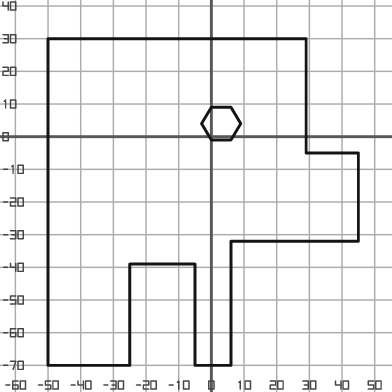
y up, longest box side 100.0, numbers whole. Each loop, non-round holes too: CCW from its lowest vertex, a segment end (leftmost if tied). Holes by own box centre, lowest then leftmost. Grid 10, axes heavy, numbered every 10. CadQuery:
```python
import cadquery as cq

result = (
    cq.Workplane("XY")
    .moveTo(-50.0, -70.0)
    .lineTo(-25.0, -70.0)
    .lineTo(-25.0, -39.0)
    .lineTo(-5.0, -39.0)
    .lineTo(-5.0, -70.0)
    .lineTo(6.0, -70.0)
    .lineTo(6.0, -32.0)
    .lineTo(45.0, -32.0)
    .lineTo(45.0, -5.0)
    .lineTo(29.0, -5.0)
    .lineTo(29.0, 30.0)
    .lineTo(-50.0, 30.0)
    .close()
    .moveTo(0.0, -1.0)
    .lineTo(6.0, -1.0)
    .lineTo(9.0, 4.0)
    .lineTo(6.0, 9.0)
    .lineTo(0.0, 9.0)
    .lineTo(-3.0, 4.0)
    .close()
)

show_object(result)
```